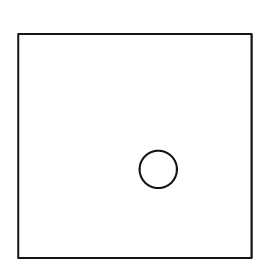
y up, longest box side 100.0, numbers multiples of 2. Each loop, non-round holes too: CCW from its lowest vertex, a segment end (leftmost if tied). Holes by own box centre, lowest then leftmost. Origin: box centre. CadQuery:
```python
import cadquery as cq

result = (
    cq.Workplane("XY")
    .moveTo(-50.0, -48.0)
    .lineTo(50.0, -48.0)
    .lineTo(50.0, 48.0)
    .lineTo(-50.0, 48.0)
    .close()
    .moveTo(10.0, -10.0)
    .circle(8.0)
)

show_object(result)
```